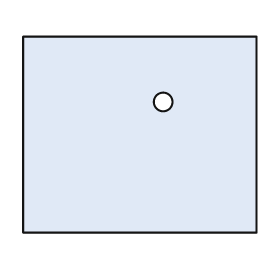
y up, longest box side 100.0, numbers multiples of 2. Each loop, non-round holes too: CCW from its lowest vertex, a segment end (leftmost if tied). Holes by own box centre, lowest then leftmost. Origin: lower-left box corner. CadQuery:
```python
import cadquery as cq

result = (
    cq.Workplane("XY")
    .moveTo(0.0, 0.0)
    .lineTo(100.0, 0.0)
    .lineTo(100.0, 84.0)
    .lineTo(0.0, 84.0)
    .close()
    .moveTo(60.0, 56.0)
    .circle(4.0)
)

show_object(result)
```